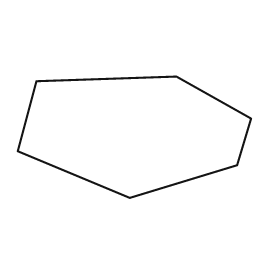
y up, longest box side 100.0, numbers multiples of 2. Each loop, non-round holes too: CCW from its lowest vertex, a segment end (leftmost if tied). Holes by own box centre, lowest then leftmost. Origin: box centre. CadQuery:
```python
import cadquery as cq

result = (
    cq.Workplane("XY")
    .moveTo(-2.0, -26.0)
    .lineTo(44.0, -12.0)
    .lineTo(50.0, 8.0)
    .lineTo(18.0, 26.0)
    .lineTo(-42.0, 24.0)
    .lineTo(-50.0, -6.0)
    .close()
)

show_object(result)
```